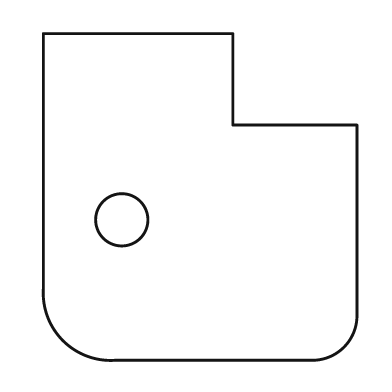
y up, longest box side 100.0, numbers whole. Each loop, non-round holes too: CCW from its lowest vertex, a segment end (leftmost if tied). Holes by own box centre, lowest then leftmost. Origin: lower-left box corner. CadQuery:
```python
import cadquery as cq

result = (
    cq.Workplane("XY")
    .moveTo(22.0, 0.0)
    .lineTo(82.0, 0.0)
    .threePointArc((92.0, 4.0), (96.0, 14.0))
    .lineTo(96.0, 72.0)
    .lineTo(58.0, 72.0)
    .lineTo(58.0, 100.0)
    .lineTo(0.0, 100.0)
    .lineTo(0.0, 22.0)
    .threePointArc((6.0, 6.0), (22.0, 0.0))
    .close()
    .moveTo(24.0, 43.0)
    .circle(8.0)
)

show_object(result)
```